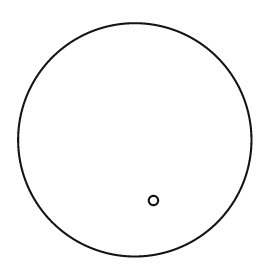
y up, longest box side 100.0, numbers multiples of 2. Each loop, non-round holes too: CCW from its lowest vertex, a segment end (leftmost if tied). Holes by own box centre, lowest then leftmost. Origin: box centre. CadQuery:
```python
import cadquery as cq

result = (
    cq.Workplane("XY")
    .moveTo(0.0, 0.0)
    .circle(50.0)
    .moveTo(8.0, -26.0)
    .circle(2.0)
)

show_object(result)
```